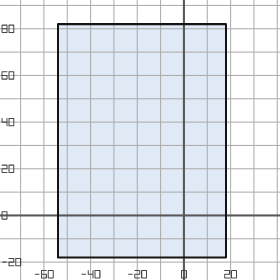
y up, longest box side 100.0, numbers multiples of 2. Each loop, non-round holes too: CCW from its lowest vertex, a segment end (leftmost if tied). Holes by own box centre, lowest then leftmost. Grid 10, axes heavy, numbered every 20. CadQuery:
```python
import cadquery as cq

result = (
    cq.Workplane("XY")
    .moveTo(-54.0, -18.0)
    .lineTo(18.0, -18.0)
    .lineTo(18.0, 82.0)
    .lineTo(-54.0, 82.0)
    .close()
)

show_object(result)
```